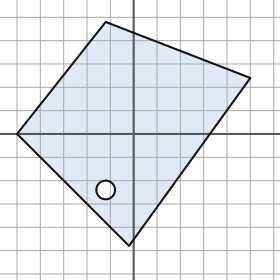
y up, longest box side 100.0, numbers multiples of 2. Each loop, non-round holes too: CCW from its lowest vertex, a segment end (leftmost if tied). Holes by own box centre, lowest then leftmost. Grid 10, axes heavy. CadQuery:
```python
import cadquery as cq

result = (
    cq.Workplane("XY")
    .moveTo(-2.0, -48.0)
    .lineTo(50.0, 24.0)
    .lineTo(-12.0, 48.0)
    .lineTo(-50.0, 0.0)
    .close()
    .moveTo(-12.0, -24.0)
    .circle(4.0)
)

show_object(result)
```